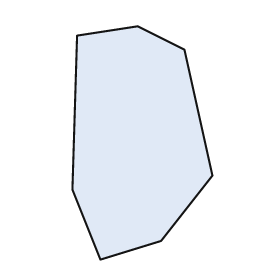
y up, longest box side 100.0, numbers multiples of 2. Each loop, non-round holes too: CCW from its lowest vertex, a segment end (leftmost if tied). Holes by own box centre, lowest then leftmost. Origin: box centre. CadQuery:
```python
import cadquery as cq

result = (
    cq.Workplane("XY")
    .moveTo(-18.0, -50.0)
    .lineTo(8.0, -42.0)
    .lineTo(30.0, -14.0)
    .lineTo(18.0, 40.0)
    .lineTo(-2.0, 50.0)
    .lineTo(-28.0, 46.0)
    .lineTo(-30.0, -20.0)
    .close()
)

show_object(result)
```